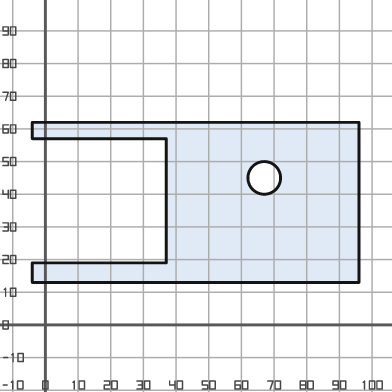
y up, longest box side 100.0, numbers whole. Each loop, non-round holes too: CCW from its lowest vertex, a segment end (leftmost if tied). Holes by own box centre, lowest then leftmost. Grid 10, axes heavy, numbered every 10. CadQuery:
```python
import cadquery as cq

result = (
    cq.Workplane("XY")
    .moveTo(-4.0, 13.0)
    .lineTo(96.0, 13.0)
    .lineTo(96.0, 62.0)
    .lineTo(-4.0, 62.0)
    .lineTo(-4.0, 57.0)
    .lineTo(37.0, 57.0)
    .lineTo(37.0, 19.0)
    .lineTo(-4.0, 19.0)
    .close()
    .moveTo(67.0, 45.0)
    .circle(5.0)
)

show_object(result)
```